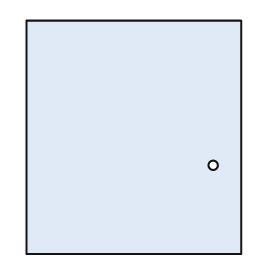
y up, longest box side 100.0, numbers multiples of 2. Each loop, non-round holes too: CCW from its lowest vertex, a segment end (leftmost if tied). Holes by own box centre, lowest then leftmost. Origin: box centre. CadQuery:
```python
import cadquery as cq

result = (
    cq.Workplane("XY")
    .moveTo(-46.0, -50.0)
    .lineTo(46.0, -50.0)
    .lineTo(46.0, 50.0)
    .lineTo(-46.0, 50.0)
    .close()
    .moveTo(34.0, -12.0)
    .circle(2.0)
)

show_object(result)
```